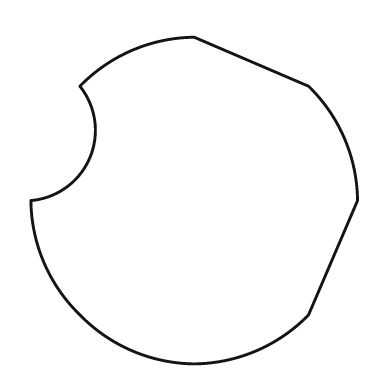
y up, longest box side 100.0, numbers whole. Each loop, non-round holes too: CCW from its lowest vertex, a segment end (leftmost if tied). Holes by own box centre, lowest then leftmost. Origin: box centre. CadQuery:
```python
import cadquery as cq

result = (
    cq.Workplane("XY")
    .moveTo(0.0, -50.0)
    .threePointArc((19.0, -46.0), (35.0, -35.0))
    .lineTo(50.0, 0.0)
    .threePointArc((46.0, 19.0), (35.0, 35.0))
    .lineTo(0.0, 50.0)
    .threePointArc((-19.0, 46.0), (-35.0, 35.0))
    .threePointArc((-32.0, 13.0), (-50.0, 0.0))
    .threePointArc((-46.0, -19.0), (-35.0, -35.0))
    .threePointArc((-19.0, -46.0), (0.0, -50.0))
    .close()
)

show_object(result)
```